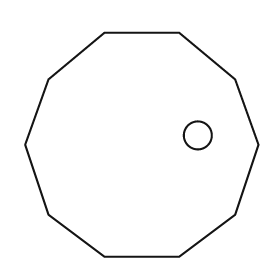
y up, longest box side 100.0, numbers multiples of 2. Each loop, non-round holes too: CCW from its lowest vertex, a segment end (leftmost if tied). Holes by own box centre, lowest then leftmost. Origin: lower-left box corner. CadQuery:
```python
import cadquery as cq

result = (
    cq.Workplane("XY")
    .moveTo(34.0, 0.0)
    .lineTo(66.0, 0.0)
    .lineTo(90.0, 18.0)
    .lineTo(100.0, 48.0)
    .lineTo(90.0, 76.0)
    .lineTo(66.0, 96.0)
    .lineTo(34.0, 96.0)
    .lineTo(10.0, 76.0)
    .lineTo(0.0, 48.0)
    .lineTo(10.0, 18.0)
    .close()
    .moveTo(74.0, 52.0)
    .circle(6.0)
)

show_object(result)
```